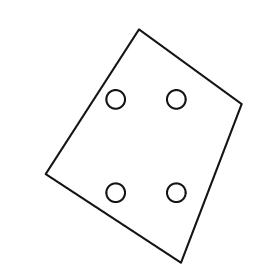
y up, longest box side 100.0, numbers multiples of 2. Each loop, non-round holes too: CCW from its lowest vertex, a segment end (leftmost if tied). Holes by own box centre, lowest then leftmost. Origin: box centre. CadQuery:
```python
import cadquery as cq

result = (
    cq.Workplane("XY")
    .moveTo(16.0, -50.0)
    .lineTo(42.0, 18.0)
    .lineTo(-2.0, 50.0)
    .lineTo(-42.0, -12.0)
    .close()
    .moveTo(-12.0, -20.0)
    .circle(4.0)
    .moveTo(14.0, -20.0)
    .circle(4.0)
    .moveTo(-12.0, 20.0)
    .circle(4.0)
    .moveTo(14.0, 20.0)
    .circle(4.0)
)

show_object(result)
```